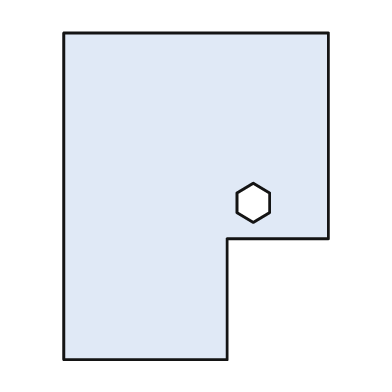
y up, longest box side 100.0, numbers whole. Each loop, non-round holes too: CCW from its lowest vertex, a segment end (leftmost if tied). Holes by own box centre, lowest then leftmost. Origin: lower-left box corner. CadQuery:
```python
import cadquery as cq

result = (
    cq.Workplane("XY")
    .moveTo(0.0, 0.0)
    .lineTo(50.0, 0.0)
    .lineTo(50.0, 37.0)
    .lineTo(81.0, 37.0)
    .lineTo(81.0, 100.0)
    .lineTo(0.0, 100.0)
    .close()
    .moveTo(58.0, 42.0)
    .lineTo(63.0, 45.0)
    .lineTo(63.0, 51.0)
    .lineTo(58.0, 54.0)
    .lineTo(53.0, 51.0)
    .lineTo(53.0, 45.0)
    .close()
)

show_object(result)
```